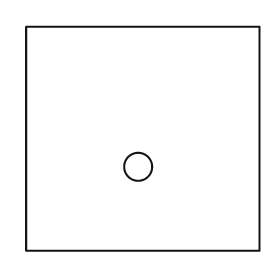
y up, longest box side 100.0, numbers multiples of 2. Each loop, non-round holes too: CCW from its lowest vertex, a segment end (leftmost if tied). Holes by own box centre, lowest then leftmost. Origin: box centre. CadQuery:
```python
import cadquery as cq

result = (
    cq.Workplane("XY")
    .moveTo(-50.0, -48.0)
    .lineTo(50.0, -48.0)
    .lineTo(50.0, 48.0)
    .lineTo(-50.0, 48.0)
    .close()
    .moveTo(-2.0, -12.0)
    .circle(6.0)
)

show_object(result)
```